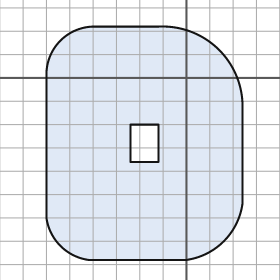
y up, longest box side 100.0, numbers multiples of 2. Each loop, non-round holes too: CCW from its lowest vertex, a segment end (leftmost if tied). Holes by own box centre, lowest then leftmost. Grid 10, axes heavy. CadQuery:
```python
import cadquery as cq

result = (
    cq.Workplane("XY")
    .moveTo(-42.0, -78.0)
    .lineTo(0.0, -78.0)
    .threePointArc((16.0, -70.0), (24.0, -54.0))
    .lineTo(24.0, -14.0)
    .threePointArc((14.0, 12.0), (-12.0, 22.0))
    .lineTo(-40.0, 22.0)
    .threePointArc((-54.0, 16.0), (-60.0, 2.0))
    .lineTo(-60.0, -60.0)
    .threePointArc((-54.0, -72.0), (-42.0, -78.0))
    .close()
    .moveTo(-24.0, -36.0)
    .lineTo(-12.0, -36.0)
    .lineTo(-12.0, -20.0)
    .lineTo(-24.0, -20.0)
    .close()
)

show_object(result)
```